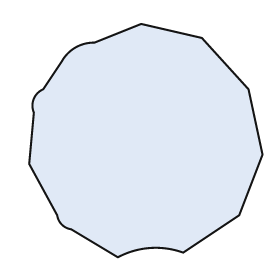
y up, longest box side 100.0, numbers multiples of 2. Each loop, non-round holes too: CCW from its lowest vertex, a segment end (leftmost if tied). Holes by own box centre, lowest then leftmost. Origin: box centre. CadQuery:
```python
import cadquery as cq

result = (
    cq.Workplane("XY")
    .moveTo(-12.0, -50.0)
    .threePointArc((2.0, -46.0), (16.0, -48.0))
    .lineTo(40.0, -32.0)
    .lineTo(50.0, -6.0)
    .lineTo(44.0, 22.0)
    .lineTo(24.0, 44.0)
    .lineTo(-2.0, 50.0)
    .lineTo(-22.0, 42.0)
    .threePointArc((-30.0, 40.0), (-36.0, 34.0))
    .lineTo(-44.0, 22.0)
    .threePointArc((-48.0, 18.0), (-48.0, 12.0))
    .lineTo(-50.0, -10.0)
    .lineTo(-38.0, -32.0)
    .threePointArc((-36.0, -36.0), (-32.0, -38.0))
    .close()
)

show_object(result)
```